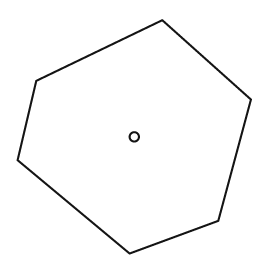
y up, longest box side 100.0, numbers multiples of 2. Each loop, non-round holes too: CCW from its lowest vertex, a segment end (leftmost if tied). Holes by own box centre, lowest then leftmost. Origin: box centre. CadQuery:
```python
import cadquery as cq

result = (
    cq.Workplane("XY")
    .moveTo(-2.0, -50.0)
    .lineTo(36.0, -36.0)
    .lineTo(50.0, 16.0)
    .lineTo(12.0, 50.0)
    .lineTo(-42.0, 24.0)
    .lineTo(-50.0, -10.0)
    .close()
    .moveTo(0.0, 0.0)
    .circle(2.0)
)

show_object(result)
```